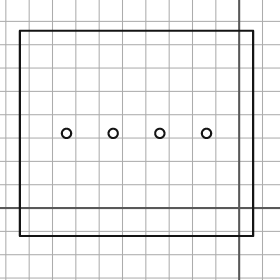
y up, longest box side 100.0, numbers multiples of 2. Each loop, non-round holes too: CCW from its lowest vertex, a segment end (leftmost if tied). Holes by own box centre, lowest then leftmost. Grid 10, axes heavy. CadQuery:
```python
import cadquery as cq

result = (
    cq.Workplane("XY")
    .moveTo(-94.0, -12.0)
    .lineTo(6.0, -12.0)
    .lineTo(6.0, 76.0)
    .lineTo(-94.0, 76.0)
    .close()
    .moveTo(-74.0, 32.0)
    .circle(2.0)
    .moveTo(-54.0, 32.0)
    .circle(2.0)
    .moveTo(-34.0, 32.0)
    .circle(2.0)
    .moveTo(-14.0, 32.0)
    .circle(2.0)
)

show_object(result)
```